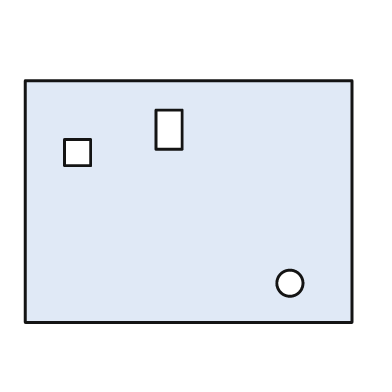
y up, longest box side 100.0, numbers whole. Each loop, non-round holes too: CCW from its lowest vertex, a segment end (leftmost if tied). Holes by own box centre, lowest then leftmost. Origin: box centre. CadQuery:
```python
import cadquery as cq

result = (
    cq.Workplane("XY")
    .moveTo(-50.0, -37.0)
    .lineTo(50.0, -37.0)
    .lineTo(50.0, 37.0)
    .lineTo(-50.0, 37.0)
    .close()
    .moveTo(31.0, -25.0)
    .circle(4.0)
    .moveTo(-38.0, 11.0)
    .lineTo(-30.0, 11.0)
    .lineTo(-30.0, 19.0)
    .lineTo(-38.0, 19.0)
    .close()
    .moveTo(-10.0, 16.0)
    .lineTo(-2.0, 16.0)
    .lineTo(-2.0, 28.0)
    .lineTo(-10.0, 28.0)
    .close()
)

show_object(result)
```